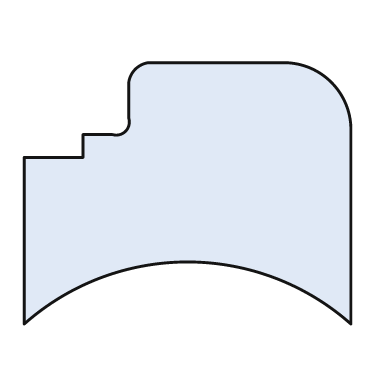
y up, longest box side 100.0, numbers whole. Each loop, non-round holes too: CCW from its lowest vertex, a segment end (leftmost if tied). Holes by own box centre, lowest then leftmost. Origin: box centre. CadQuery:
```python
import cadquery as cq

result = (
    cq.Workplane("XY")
    .moveTo(-50.0, -40.0)
    .threePointArc((0.0, -21.0), (50.0, -40.0))
    .lineTo(50.0, 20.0)
    .threePointArc((44.0, 34.0), (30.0, 40.0))
    .lineTo(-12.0, 40.0)
    .threePointArc((-16.0, 38.0), (-18.0, 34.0))
    .lineTo(-18.0, 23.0)
    .threePointArc((-19.0, 19.0), (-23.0, 18.0))
    .lineTo(-32.0, 18.0)
    .lineTo(-32.0, 11.0)
    .lineTo(-50.0, 11.0)
    .close()
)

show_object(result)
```